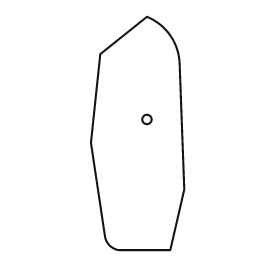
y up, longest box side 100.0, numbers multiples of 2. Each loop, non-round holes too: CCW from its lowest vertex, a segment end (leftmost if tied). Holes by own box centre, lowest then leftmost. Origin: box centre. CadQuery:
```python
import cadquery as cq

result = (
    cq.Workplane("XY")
    .moveTo(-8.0, -50.0)
    .lineTo(14.0, -50.0)
    .lineTo(20.0, -24.0)
    .lineTo(18.0, 30.0)
    .threePointArc((14.0, 42.0), (4.0, 50.0))
    .lineTo(-16.0, 34.0)
    .lineTo(-20.0, -4.0)
    .lineTo(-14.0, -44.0)
    .threePointArc((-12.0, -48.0), (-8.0, -50.0))
    .close()
    .moveTo(4.0, 6.0)
    .circle(2.0)
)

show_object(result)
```